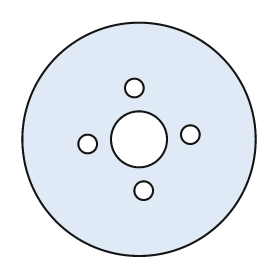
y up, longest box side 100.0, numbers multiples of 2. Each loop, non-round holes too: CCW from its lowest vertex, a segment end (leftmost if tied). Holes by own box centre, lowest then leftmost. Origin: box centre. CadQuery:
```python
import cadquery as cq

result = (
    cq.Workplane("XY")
    .moveTo(0.0, 0.0)
    .circle(50.0)
    .moveTo(2.0, -22.0)
    .circle(4.0)
    .moveTo(-22.0, -2.0)
    .circle(4.0)
    .moveTo(0.0, 0.0)
    .circle(12.0)
    .moveTo(22.0, 2.0)
    .circle(4.0)
    .moveTo(-2.0, 22.0)
    .circle(4.0)
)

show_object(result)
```